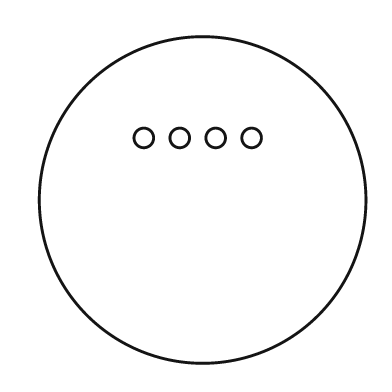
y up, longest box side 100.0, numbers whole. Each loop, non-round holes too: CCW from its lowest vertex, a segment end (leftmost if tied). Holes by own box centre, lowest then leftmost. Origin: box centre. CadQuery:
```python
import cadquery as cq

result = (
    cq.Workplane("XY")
    .moveTo(0.0, 0.0)
    .circle(50.0)
    .moveTo(-18.0, 19.0)
    .circle(3.0)
    .moveTo(-7.0, 19.0)
    .circle(3.0)
    .moveTo(4.0, 19.0)
    .circle(3.0)
    .moveTo(15.0, 19.0)
    .circle(3.0)
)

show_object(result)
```